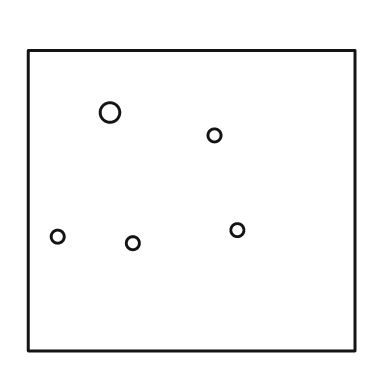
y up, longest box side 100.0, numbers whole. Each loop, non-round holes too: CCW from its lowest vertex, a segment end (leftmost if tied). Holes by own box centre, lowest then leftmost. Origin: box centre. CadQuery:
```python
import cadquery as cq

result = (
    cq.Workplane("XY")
    .moveTo(-50.0, -46.0)
    .lineTo(50.0, -46.0)
    .lineTo(50.0, 46.0)
    .lineTo(-50.0, 46.0)
    .close()
    .moveTo(-18.0, -13.0)
    .circle(2.0)
    .moveTo(-41.0, -11.0)
    .circle(2.0)
    .moveTo(14.0, -9.0)
    .circle(2.0)
    .moveTo(7.0, 20.0)
    .circle(2.0)
    .moveTo(-25.0, 27.0)
    .circle(3.0)
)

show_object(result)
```